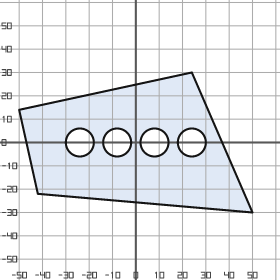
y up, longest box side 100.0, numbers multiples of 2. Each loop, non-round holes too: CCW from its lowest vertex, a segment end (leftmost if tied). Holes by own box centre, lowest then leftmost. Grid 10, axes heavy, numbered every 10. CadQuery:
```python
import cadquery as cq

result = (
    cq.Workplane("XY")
    .moveTo(50.0, -30.0)
    .lineTo(24.0, 30.0)
    .lineTo(-50.0, 14.0)
    .lineTo(-42.0, -22.0)
    .close()
    .moveTo(-24.0, 0.0)
    .circle(6.0)
    .moveTo(-8.0, 0.0)
    .circle(6.0)
    .moveTo(8.0, 0.0)
    .circle(6.0)
    .moveTo(24.0, 0.0)
    .circle(6.0)
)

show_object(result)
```